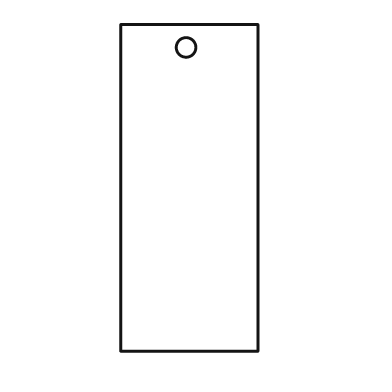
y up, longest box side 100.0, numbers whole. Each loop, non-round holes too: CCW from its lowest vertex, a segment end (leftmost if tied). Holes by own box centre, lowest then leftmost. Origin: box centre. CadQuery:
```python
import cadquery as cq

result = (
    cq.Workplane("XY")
    .moveTo(-21.0, -50.0)
    .lineTo(21.0, -50.0)
    .lineTo(21.0, 50.0)
    .lineTo(-21.0, 50.0)
    .close()
    .moveTo(-1.0, 43.0)
    .circle(3.0)
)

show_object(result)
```